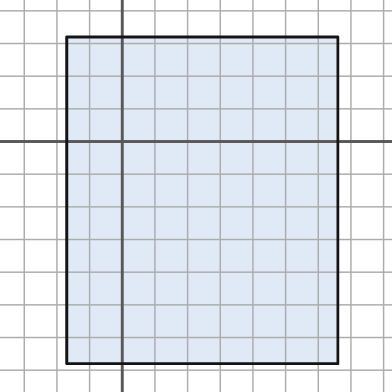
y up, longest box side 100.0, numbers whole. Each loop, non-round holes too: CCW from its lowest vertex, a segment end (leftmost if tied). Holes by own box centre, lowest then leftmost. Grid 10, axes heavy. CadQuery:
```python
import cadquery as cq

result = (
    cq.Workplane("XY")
    .moveTo(-17.0, -68.0)
    .lineTo(66.0, -68.0)
    .lineTo(66.0, 32.0)
    .lineTo(-17.0, 32.0)
    .close()
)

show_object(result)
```